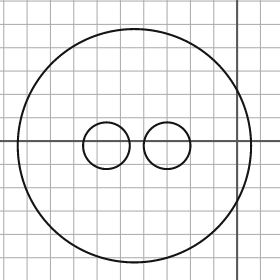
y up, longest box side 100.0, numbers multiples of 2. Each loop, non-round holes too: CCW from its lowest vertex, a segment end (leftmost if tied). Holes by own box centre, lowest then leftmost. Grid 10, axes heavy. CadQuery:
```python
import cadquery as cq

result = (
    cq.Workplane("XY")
    .moveTo(-44.0, -2.0)
    .circle(50.0)
    .moveTo(-56.0, -2.0)
    .circle(10.0)
    .moveTo(-30.0, -2.0)
    .circle(10.0)
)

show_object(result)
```